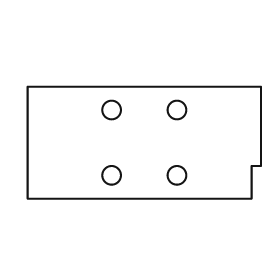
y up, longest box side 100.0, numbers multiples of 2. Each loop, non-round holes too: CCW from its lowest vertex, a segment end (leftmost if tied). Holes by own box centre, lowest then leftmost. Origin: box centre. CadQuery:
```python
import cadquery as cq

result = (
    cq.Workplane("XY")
    .moveTo(-50.0, -24.0)
    .lineTo(46.0, -24.0)
    .lineTo(46.0, -10.0)
    .lineTo(50.0, -10.0)
    .lineTo(50.0, 24.0)
    .lineTo(-50.0, 24.0)
    .close()
    .moveTo(-14.0, -14.0)
    .circle(4.0)
    .moveTo(14.0, -14.0)
    .circle(4.0)
    .moveTo(-14.0, 14.0)
    .circle(4.0)
    .moveTo(14.0, 14.0)
    .circle(4.0)
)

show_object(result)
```